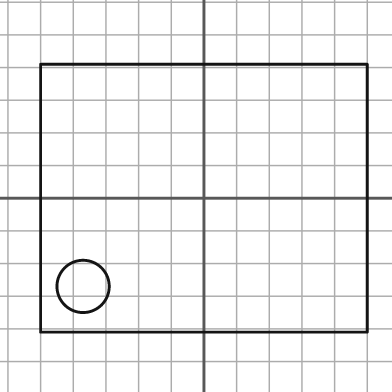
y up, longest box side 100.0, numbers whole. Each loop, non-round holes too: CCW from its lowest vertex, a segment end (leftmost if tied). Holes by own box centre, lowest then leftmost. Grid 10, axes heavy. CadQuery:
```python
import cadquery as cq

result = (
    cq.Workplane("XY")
    .moveTo(-50.0, -41.0)
    .lineTo(50.0, -41.0)
    .lineTo(50.0, 41.0)
    .lineTo(-50.0, 41.0)
    .close()
    .moveTo(-37.0, -27.0)
    .circle(8.0)
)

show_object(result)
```